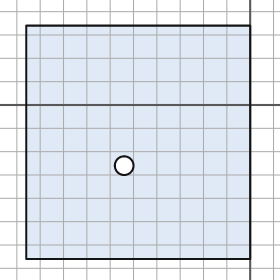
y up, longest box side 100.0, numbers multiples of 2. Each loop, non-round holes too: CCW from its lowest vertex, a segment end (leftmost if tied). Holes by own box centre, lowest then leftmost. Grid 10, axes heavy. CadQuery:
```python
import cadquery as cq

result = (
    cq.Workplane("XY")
    .moveTo(-96.0, -66.0)
    .lineTo(0.0, -66.0)
    .lineTo(0.0, 34.0)
    .lineTo(-96.0, 34.0)
    .close()
    .moveTo(-54.0, -26.0)
    .circle(4.0)
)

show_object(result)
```